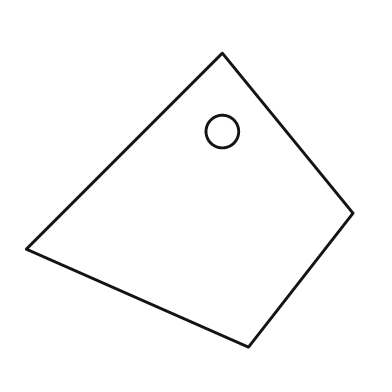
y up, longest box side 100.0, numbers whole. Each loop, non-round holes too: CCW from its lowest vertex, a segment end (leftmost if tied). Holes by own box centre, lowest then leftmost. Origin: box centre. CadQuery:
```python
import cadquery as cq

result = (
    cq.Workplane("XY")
    .moveTo(18.0, -45.0)
    .lineTo(50.0, -4.0)
    .lineTo(10.0, 45.0)
    .lineTo(-50.0, -15.0)
    .close()
    .moveTo(10.0, 21.0)
    .circle(5.0)
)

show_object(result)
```